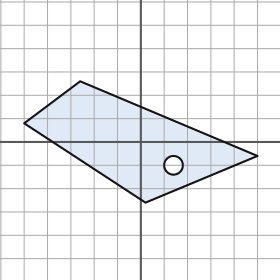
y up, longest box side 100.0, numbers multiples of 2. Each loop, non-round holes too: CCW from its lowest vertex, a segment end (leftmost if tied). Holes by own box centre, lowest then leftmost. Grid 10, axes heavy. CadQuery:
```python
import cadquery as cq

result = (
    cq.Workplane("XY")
    .moveTo(2.0, -26.0)
    .lineTo(50.0, -6.0)
    .lineTo(-26.0, 26.0)
    .lineTo(-50.0, 8.0)
    .close()
    .moveTo(14.0, -10.0)
    .circle(4.0)
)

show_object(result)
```